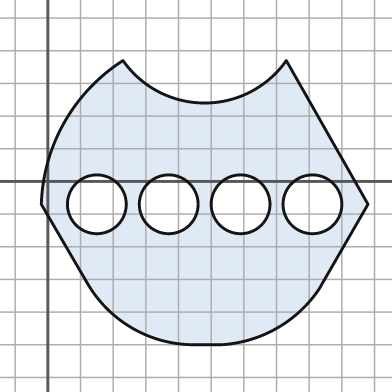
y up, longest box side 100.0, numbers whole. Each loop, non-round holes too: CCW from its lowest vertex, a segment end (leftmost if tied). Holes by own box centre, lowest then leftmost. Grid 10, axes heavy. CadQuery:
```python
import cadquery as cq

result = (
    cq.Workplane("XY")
    .moveTo(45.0, -50.0)
    .lineTo(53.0, -50.0)
    .threePointArc((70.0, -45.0), (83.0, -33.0))
    .lineTo(98.0, -7.0)
    .lineTo(73.0, 37.0)
    .threePointArc((48.0, 24.0), (23.0, 37.0))
    .threePointArc((5.0, 18.0), (-2.0, -7.0))
    .lineTo(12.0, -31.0)
    .threePointArc((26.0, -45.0), (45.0, -50.0))
    .close()
    .moveTo(15.0, -7.0)
    .circle(9.0)
    .moveTo(37.0, -7.0)
    .circle(9.0)
    .moveTo(59.0, -7.0)
    .circle(9.0)
    .moveTo(81.0, -7.0)
    .circle(9.0)
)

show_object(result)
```